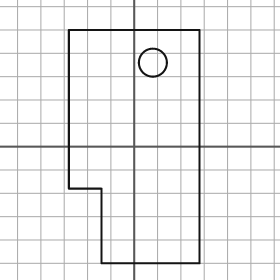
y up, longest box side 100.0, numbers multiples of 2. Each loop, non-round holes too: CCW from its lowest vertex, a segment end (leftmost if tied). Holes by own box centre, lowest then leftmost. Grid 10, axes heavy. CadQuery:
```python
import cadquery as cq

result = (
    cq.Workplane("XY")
    .moveTo(-14.0, -50.0)
    .lineTo(28.0, -50.0)
    .lineTo(28.0, 50.0)
    .lineTo(-28.0, 50.0)
    .lineTo(-28.0, -18.0)
    .lineTo(-14.0, -18.0)
    .close()
    .moveTo(8.0, 36.0)
    .circle(6.0)
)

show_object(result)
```